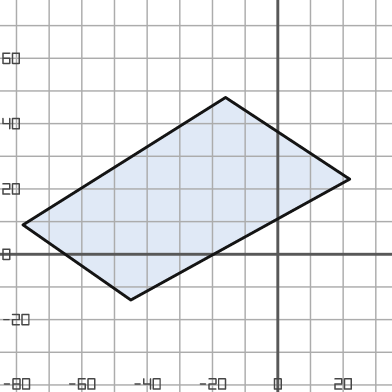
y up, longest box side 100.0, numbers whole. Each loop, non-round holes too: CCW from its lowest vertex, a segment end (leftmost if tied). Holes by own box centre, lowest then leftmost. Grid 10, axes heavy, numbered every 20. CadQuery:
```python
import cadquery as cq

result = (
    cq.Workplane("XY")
    .moveTo(-45.0, -14.0)
    .lineTo(22.0, 23.0)
    .lineTo(-16.0, 48.0)
    .lineTo(-78.0, 9.0)
    .close()
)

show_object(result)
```